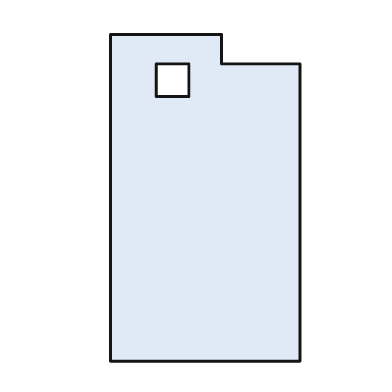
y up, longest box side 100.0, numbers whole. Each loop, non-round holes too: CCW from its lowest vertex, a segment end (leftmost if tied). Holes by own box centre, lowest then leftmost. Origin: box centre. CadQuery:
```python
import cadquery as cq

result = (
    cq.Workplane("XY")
    .moveTo(-29.0, -50.0)
    .lineTo(29.0, -50.0)
    .lineTo(29.0, 41.0)
    .lineTo(5.0, 41.0)
    .lineTo(5.0, 50.0)
    .lineTo(-29.0, 50.0)
    .close()
    .moveTo(-15.0, 31.0)
    .lineTo(-5.0, 31.0)
    .lineTo(-5.0, 41.0)
    .lineTo(-15.0, 41.0)
    .close()
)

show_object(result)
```